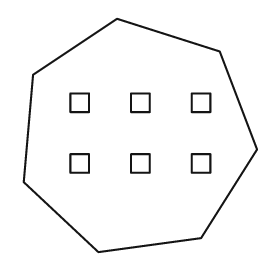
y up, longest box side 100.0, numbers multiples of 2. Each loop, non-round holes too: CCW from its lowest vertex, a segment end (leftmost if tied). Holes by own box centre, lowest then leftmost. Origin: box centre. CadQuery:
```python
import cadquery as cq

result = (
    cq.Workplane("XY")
    .moveTo(-18.0, -50.0)
    .lineTo(26.0, -44.0)
    .lineTo(50.0, -6.0)
    .lineTo(34.0, 36.0)
    .lineTo(-10.0, 50.0)
    .lineTo(-46.0, 26.0)
    .lineTo(-50.0, -20.0)
    .close()
    .moveTo(-30.0, -16.0)
    .lineTo(-22.0, -16.0)
    .lineTo(-22.0, -8.0)
    .lineTo(-30.0, -8.0)
    .close()
    .moveTo(-4.0, -16.0)
    .lineTo(4.0, -16.0)
    .lineTo(4.0, -8.0)
    .lineTo(-4.0, -8.0)
    .close()
    .moveTo(22.0, -16.0)
    .lineTo(30.0, -16.0)
    .lineTo(30.0, -8.0)
    .lineTo(22.0, -8.0)
    .close()
    .moveTo(-30.0, 10.0)
    .lineTo(-22.0, 10.0)
    .lineTo(-22.0, 18.0)
    .lineTo(-30.0, 18.0)
    .close()
    .moveTo(-4.0, 10.0)
    .lineTo(4.0, 10.0)
    .lineTo(4.0, 18.0)
    .lineTo(-4.0, 18.0)
    .close()
    .moveTo(22.0, 10.0)
    .lineTo(30.0, 10.0)
    .lineTo(30.0, 18.0)
    .lineTo(22.0, 18.0)
    .close()
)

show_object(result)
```